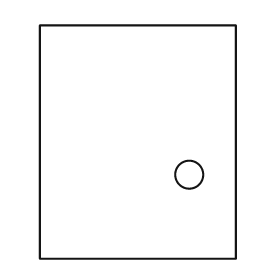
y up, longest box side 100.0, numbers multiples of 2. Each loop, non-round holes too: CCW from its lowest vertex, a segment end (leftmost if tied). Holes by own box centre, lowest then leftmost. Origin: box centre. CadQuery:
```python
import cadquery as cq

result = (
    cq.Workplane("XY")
    .moveTo(-42.0, -50.0)
    .lineTo(42.0, -50.0)
    .lineTo(42.0, 50.0)
    .lineTo(-42.0, 50.0)
    .close()
    .moveTo(22.0, -14.0)
    .circle(6.0)
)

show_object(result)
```